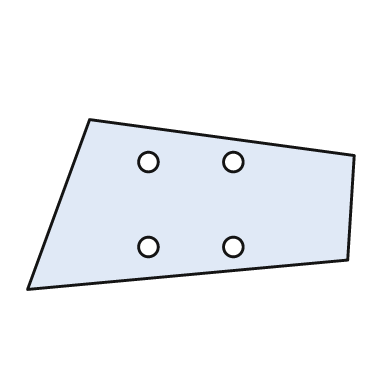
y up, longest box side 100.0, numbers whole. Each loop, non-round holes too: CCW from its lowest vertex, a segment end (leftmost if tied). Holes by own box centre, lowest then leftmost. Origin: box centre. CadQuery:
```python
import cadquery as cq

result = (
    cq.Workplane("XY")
    .moveTo(-50.0, -26.0)
    .lineTo(48.0, -17.0)
    .lineTo(50.0, 15.0)
    .lineTo(-31.0, 26.0)
    .close()
    .moveTo(-13.0, -13.0)
    .circle(3.0)
    .moveTo(13.0, -13.0)
    .circle(3.0)
    .moveTo(-13.0, 13.0)
    .circle(3.0)
    .moveTo(13.0, 13.0)
    .circle(3.0)
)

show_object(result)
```